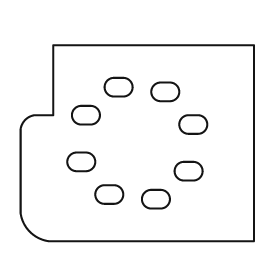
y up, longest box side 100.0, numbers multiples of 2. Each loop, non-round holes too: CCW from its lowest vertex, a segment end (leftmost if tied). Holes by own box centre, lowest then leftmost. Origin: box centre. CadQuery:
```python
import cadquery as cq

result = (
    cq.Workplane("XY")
    .moveTo(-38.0, -42.0)
    .lineTo(50.0, -42.0)
    .lineTo(50.0, 42.0)
    .lineTo(-36.0, 42.0)
    .lineTo(-36.0, 12.0)
    .lineTo(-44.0, 12.0)
    .threePointArc((-48.0, 10.0), (-50.0, 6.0))
    .lineTo(-50.0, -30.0)
    .threePointArc((-46.0, -38.0), (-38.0, -42.0))
    .close()
    .moveTo(6.0, -28.0)
    .lineTo(10.0, -28.0)
    .threePointArc((14.0, -24.0), (10.0, -20.0))
    .lineTo(6.0, -20.0)
    .threePointArc((2.0, -24.0), (6.0, -28.0))
    .close()
    .moveTo(-14.0, -26.0)
    .lineTo(-10.0, -26.0)
    .threePointArc((-6.0, -22.0), (-10.0, -18.0))
    .lineTo(-14.0, -18.0)
    .threePointArc((-18.0, -22.0), (-14.0, -26.0))
    .close()
    .moveTo(20.0, -16.0)
    .lineTo(24.0, -16.0)
    .threePointArc((28.0, -12.0), (24.0, -8.0))
    .lineTo(20.0, -8.0)
    .threePointArc((16.0, -12.0), (20.0, -16.0))
    .close()
    .moveTo(-26.0, -12.0)
    .lineTo(-22.0, -12.0)
    .threePointArc((-18.0, -8.0), (-22.0, -4.0))
    .lineTo(-26.0, -4.0)
    .threePointArc((-30.0, -8.0), (-26.0, -12.0))
    .close()
    .moveTo(22.0, 4.0)
    .lineTo(26.0, 4.0)
    .threePointArc((30.0, 8.0), (26.0, 12.0))
    .lineTo(22.0, 12.0)
    .threePointArc((18.0, 8.0), (22.0, 4.0))
    .close()
    .moveTo(-24.0, 8.0)
    .lineTo(-20.0, 8.0)
    .threePointArc((-16.0, 12.0), (-20.0, 16.0))
    .lineTo(-24.0, 16.0)
    .threePointArc((-28.0, 12.0), (-24.0, 8.0))
    .close()
    .moveTo(10.0, 18.0)
    .lineTo(14.0, 18.0)
    .threePointArc((18.0, 22.0), (14.0, 26.0))
    .lineTo(10.0, 26.0)
    .threePointArc((6.0, 22.0), (10.0, 18.0))
    .close()
    .moveTo(-10.0, 20.0)
    .lineTo(-6.0, 20.0)
    .threePointArc((-2.0, 24.0), (-6.0, 28.0))
    .lineTo(-10.0, 28.0)
    .threePointArc((-14.0, 24.0), (-10.0, 20.0))
    .close()
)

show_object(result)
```